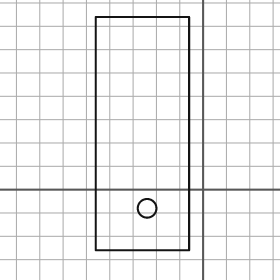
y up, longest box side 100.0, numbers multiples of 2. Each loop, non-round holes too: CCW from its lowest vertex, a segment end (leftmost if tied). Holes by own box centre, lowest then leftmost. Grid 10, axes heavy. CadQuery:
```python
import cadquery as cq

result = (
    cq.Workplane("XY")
    .moveTo(-46.0, -26.0)
    .lineTo(-6.0, -26.0)
    .lineTo(-6.0, 74.0)
    .lineTo(-46.0, 74.0)
    .close()
    .moveTo(-24.0, -8.0)
    .circle(4.0)
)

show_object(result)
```